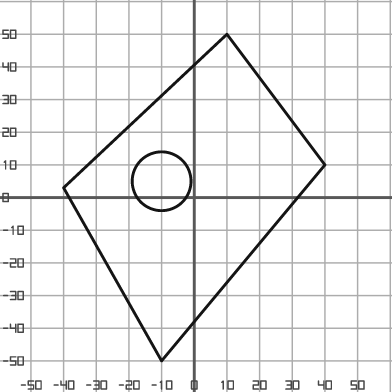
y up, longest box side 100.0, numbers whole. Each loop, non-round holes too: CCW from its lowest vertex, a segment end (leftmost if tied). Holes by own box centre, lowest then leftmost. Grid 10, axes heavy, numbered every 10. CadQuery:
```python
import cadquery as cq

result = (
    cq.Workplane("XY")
    .moveTo(-10.0, -50.0)
    .lineTo(40.0, 10.0)
    .lineTo(10.0, 50.0)
    .lineTo(-40.0, 3.0)
    .close()
    .moveTo(-10.0, 5.0)
    .circle(9.0)
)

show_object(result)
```